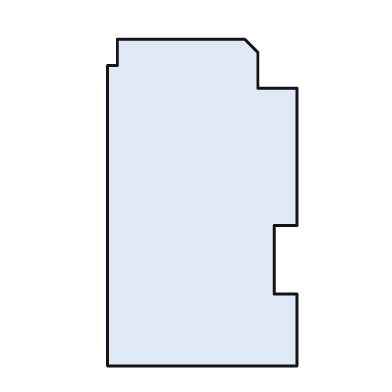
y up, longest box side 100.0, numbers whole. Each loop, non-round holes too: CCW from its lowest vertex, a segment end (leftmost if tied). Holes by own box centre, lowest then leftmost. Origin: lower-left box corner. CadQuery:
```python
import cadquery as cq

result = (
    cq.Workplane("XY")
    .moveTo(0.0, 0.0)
    .lineTo(58.0, 0.0)
    .lineTo(58.0, 22.0)
    .lineTo(51.0, 22.0)
    .lineTo(51.0, 43.0)
    .lineTo(58.0, 43.0)
    .lineTo(58.0, 85.0)
    .lineTo(46.0, 85.0)
    .lineTo(46.0, 96.0)
    .lineTo(42.0, 100.0)
    .lineTo(3.0, 100.0)
    .lineTo(3.0, 92.0)
    .lineTo(0.0, 92.0)
    .close()
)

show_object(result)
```